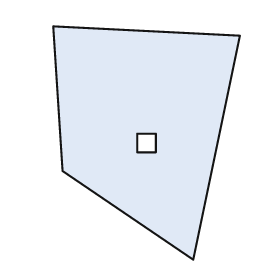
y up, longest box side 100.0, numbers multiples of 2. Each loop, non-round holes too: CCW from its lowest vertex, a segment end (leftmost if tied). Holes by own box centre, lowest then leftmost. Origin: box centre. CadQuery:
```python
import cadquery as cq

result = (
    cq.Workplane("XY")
    .moveTo(20.0, -50.0)
    .lineTo(40.0, 46.0)
    .lineTo(-40.0, 50.0)
    .lineTo(-36.0, -12.0)
    .close()
    .moveTo(-4.0, -4.0)
    .lineTo(4.0, -4.0)
    .lineTo(4.0, 4.0)
    .lineTo(-4.0, 4.0)
    .close()
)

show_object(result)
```